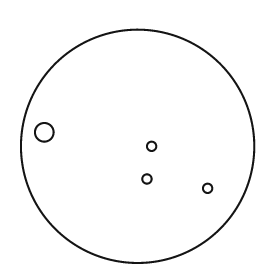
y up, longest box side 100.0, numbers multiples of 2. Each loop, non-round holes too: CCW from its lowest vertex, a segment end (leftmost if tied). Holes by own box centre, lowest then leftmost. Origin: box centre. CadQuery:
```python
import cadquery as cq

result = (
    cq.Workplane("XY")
    .moveTo(0.0, 0.0)
    .circle(50.0)
    .moveTo(30.0, -18.0)
    .circle(2.0)
    .moveTo(4.0, -14.0)
    .circle(2.0)
    .moveTo(6.0, 0.0)
    .circle(2.0)
    .moveTo(-40.0, 6.0)
    .circle(4.0)
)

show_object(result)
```